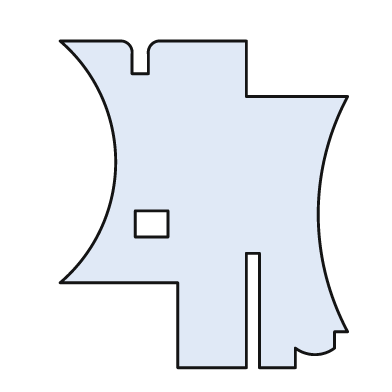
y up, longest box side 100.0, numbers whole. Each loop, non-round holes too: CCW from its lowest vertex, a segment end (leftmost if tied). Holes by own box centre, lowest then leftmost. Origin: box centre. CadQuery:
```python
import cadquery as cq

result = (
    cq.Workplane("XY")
    .moveTo(-8.0, -50.0)
    .lineTo(13.0, -50.0)
    .lineTo(13.0, -15.0)
    .lineTo(17.0, -15.0)
    .lineTo(17.0, -50.0)
    .lineTo(28.0, -50.0)
    .lineTo(28.0, -44.0)
    .threePointArc((34.0, -46.0), (40.0, -44.0))
    .lineTo(40.0, -39.0)
    .lineTo(44.0, -39.0)
    .threePointArc((35.0, -3.0), (44.0, 33.0))
    .lineTo(13.0, 33.0)
    .lineTo(13.0, 50.0)
    .lineTo(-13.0, 50.0)
    .threePointArc((-16.0, 49.0), (-17.0, 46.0))
    .lineTo(-17.0, 40.0)
    .lineTo(-22.0, 40.0)
    .lineTo(-22.0, 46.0)
    .threePointArc((-23.0, 49.0), (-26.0, 50.0))
    .lineTo(-44.0, 50.0)
    .threePointArc((-27.0, 13.0), (-44.0, -24.0))
    .lineTo(-8.0, -24.0)
    .close()
    .moveTo(-21.0, -10.0)
    .lineTo(-11.0, -10.0)
    .lineTo(-11.0, -2.0)
    .lineTo(-21.0, -2.0)
    .close()
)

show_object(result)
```